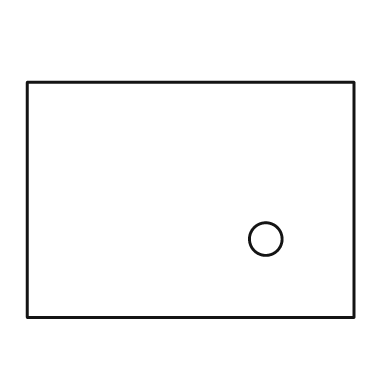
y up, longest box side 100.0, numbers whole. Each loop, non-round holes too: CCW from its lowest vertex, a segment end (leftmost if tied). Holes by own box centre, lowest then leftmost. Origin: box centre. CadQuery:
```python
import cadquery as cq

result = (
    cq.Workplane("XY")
    .moveTo(-50.0, -36.0)
    .lineTo(50.0, -36.0)
    .lineTo(50.0, 36.0)
    .lineTo(-50.0, 36.0)
    .close()
    .moveTo(23.0, -12.0)
    .circle(5.0)
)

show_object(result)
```